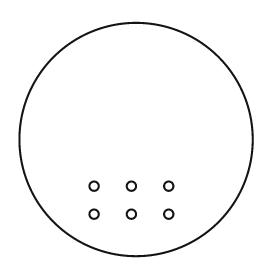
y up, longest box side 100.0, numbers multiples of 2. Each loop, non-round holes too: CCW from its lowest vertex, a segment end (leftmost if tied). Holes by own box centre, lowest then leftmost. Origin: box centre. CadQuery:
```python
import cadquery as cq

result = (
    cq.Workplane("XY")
    .moveTo(0.0, 0.0)
    .circle(50.0)
    .moveTo(-18.0, -32.0)
    .circle(2.0)
    .moveTo(-2.0, -32.0)
    .circle(2.0)
    .moveTo(14.0, -32.0)
    .circle(2.0)
    .moveTo(-18.0, -20.0)
    .circle(2.0)
    .moveTo(-2.0, -20.0)
    .circle(2.0)
    .moveTo(14.0, -20.0)
    .circle(2.0)
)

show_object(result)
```